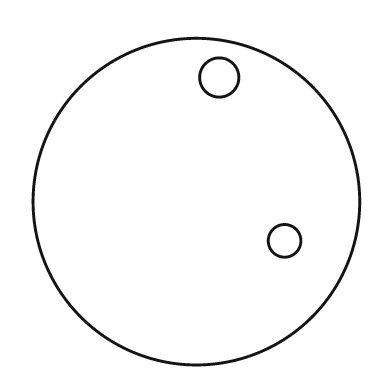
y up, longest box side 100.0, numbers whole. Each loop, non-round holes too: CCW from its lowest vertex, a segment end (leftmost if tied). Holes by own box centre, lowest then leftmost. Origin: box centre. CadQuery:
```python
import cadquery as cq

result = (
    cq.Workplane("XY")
    .moveTo(0.0, 0.0)
    .circle(50.0)
    .moveTo(27.0, -12.0)
    .circle(5.0)
    .moveTo(7.0, 38.0)
    .circle(6.0)
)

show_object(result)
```